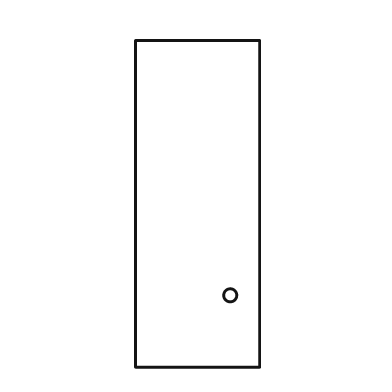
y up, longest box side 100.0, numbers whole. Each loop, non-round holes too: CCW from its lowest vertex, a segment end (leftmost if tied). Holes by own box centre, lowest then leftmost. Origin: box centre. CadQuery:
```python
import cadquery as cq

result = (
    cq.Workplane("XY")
    .moveTo(-19.0, -50.0)
    .lineTo(19.0, -50.0)
    .lineTo(19.0, 50.0)
    .lineTo(-19.0, 50.0)
    .close()
    .moveTo(10.0, -28.0)
    .circle(2.0)
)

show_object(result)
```